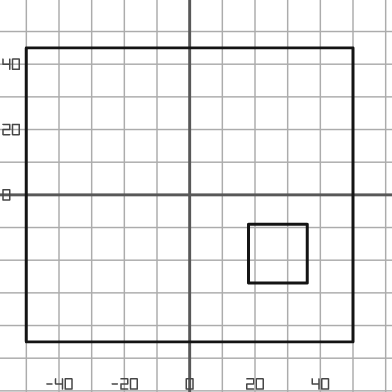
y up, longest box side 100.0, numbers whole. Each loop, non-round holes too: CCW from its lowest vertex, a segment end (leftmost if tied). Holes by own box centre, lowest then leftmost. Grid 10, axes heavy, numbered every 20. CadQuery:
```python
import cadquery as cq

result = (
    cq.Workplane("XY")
    .moveTo(-50.0, -45.0)
    .lineTo(50.0, -45.0)
    .lineTo(50.0, 45.0)
    .lineTo(-50.0, 45.0)
    .close()
    .moveTo(18.0, -27.0)
    .lineTo(36.0, -27.0)
    .lineTo(36.0, -9.0)
    .lineTo(18.0, -9.0)
    .close()
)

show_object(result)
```